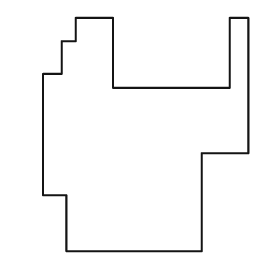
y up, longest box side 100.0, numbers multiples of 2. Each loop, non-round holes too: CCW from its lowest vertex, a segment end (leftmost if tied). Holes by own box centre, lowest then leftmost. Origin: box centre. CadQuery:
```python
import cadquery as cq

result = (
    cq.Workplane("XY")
    .moveTo(-34.0, -50.0)
    .lineTo(24.0, -50.0)
    .lineTo(24.0, -8.0)
    .lineTo(44.0, -8.0)
    .lineTo(44.0, 50.0)
    .lineTo(36.0, 50.0)
    .lineTo(36.0, 20.0)
    .lineTo(-14.0, 20.0)
    .lineTo(-14.0, 50.0)
    .lineTo(-30.0, 50.0)
    .lineTo(-30.0, 40.0)
    .lineTo(-36.0, 40.0)
    .lineTo(-36.0, 26.0)
    .lineTo(-44.0, 26.0)
    .lineTo(-44.0, -26.0)
    .lineTo(-34.0, -26.0)
    .close()
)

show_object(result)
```